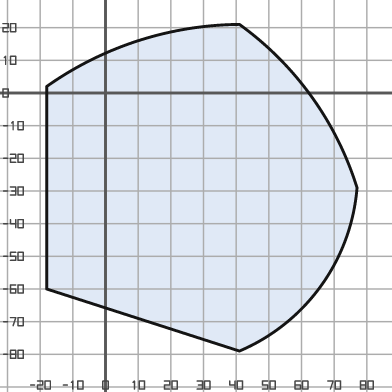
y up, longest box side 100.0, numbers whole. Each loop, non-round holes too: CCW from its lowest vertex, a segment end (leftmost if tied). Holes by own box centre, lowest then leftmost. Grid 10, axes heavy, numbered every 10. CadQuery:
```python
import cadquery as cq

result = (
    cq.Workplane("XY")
    .moveTo(41.0, -79.0)
    .threePointArc((66.0, -59.0), (77.0, -29.0))
    .threePointArc((63.0, -1.0), (41.0, 21.0))
    .threePointArc((10.0, 16.0), (-18.0, 2.0))
    .lineTo(-18.0, -60.0)
    .close()
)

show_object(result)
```